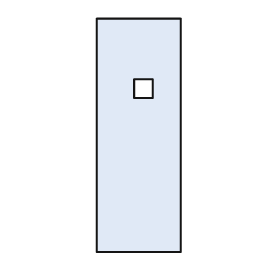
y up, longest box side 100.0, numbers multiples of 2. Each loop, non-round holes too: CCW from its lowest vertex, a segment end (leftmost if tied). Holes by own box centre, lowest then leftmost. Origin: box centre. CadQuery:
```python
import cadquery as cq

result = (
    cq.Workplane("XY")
    .moveTo(-18.0, -50.0)
    .lineTo(18.0, -50.0)
    .lineTo(18.0, 50.0)
    .lineTo(-18.0, 50.0)
    .close()
    .moveTo(-2.0, 16.0)
    .lineTo(6.0, 16.0)
    .lineTo(6.0, 24.0)
    .lineTo(-2.0, 24.0)
    .close()
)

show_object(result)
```